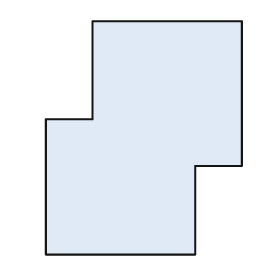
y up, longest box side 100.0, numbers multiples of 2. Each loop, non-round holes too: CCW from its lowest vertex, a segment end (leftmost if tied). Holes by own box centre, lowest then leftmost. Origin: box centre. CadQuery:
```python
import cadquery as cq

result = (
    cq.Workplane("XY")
    .moveTo(-42.0, -50.0)
    .lineTo(22.0, -50.0)
    .lineTo(22.0, -12.0)
    .lineTo(42.0, -12.0)
    .lineTo(42.0, 50.0)
    .lineTo(-22.0, 50.0)
    .lineTo(-22.0, 8.0)
    .lineTo(-42.0, 8.0)
    .close()
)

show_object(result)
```